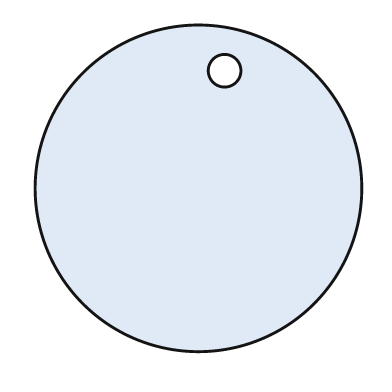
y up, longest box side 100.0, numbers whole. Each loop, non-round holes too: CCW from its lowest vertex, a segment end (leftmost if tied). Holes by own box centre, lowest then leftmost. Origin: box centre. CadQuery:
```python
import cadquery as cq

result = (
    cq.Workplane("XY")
    .moveTo(0.0, 0.0)
    .circle(50.0)
    .moveTo(8.0, 36.0)
    .circle(5.0)
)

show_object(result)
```